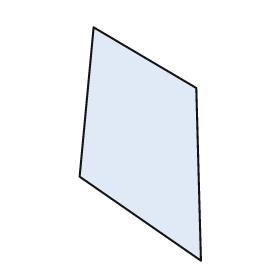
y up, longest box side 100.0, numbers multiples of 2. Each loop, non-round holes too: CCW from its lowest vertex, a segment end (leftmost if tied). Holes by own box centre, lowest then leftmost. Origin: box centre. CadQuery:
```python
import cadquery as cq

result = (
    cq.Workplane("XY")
    .moveTo(26.0, -50.0)
    .lineTo(24.0, 24.0)
    .lineTo(-20.0, 50.0)
    .lineTo(-26.0, -14.0)
    .close()
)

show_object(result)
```